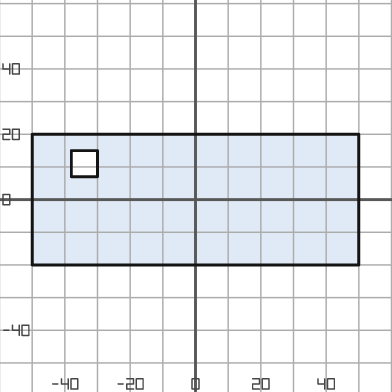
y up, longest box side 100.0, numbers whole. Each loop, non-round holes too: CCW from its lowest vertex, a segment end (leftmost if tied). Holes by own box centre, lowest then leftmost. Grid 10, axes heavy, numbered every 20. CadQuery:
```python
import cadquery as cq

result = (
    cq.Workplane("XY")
    .moveTo(-50.0, -20.0)
    .lineTo(50.0, -20.0)
    .lineTo(50.0, 20.0)
    .lineTo(-50.0, 20.0)
    .close()
    .moveTo(-38.0, 7.0)
    .lineTo(-30.0, 7.0)
    .lineTo(-30.0, 15.0)
    .lineTo(-38.0, 15.0)
    .close()
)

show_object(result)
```